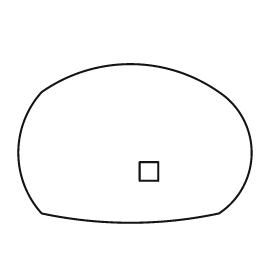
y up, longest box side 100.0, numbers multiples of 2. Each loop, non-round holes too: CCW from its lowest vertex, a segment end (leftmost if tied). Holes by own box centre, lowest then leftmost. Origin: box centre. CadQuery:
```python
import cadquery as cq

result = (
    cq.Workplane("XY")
    .moveTo(-40.0, -30.0)
    .threePointArc((-2.0, -34.0), (36.0, -30.0))
    .threePointArc((50.0, -4.0), (36.0, 22.0))
    .threePointArc((-2.0, 34.0), (-40.0, 22.0))
    .threePointArc((-50.0, -4.0), (-40.0, -30.0))
    .close()
    .moveTo(2.0, -16.0)
    .lineTo(10.0, -16.0)
    .lineTo(10.0, -8.0)
    .lineTo(2.0, -8.0)
    .close()
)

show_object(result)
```